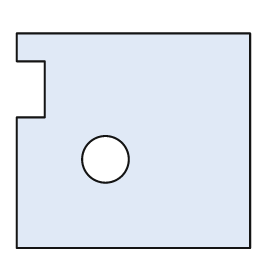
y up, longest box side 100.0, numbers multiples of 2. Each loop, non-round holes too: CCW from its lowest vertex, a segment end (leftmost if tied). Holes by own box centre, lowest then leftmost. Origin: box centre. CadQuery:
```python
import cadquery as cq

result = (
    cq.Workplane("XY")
    .moveTo(-50.0, -46.0)
    .lineTo(50.0, -46.0)
    .lineTo(50.0, 46.0)
    .lineTo(-50.0, 46.0)
    .lineTo(-50.0, 34.0)
    .lineTo(-38.0, 34.0)
    .lineTo(-38.0, 10.0)
    .lineTo(-50.0, 10.0)
    .close()
    .moveTo(-12.0, -8.0)
    .circle(10.0)
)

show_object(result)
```